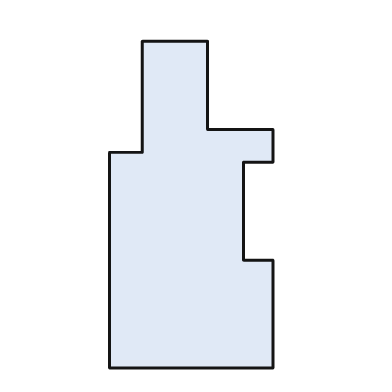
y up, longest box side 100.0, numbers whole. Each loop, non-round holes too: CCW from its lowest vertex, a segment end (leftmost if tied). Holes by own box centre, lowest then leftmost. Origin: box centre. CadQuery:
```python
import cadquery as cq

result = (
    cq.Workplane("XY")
    .moveTo(-25.0, -50.0)
    .lineTo(25.0, -50.0)
    .lineTo(25.0, -17.0)
    .lineTo(16.0, -17.0)
    .lineTo(16.0, 13.0)
    .lineTo(25.0, 13.0)
    .lineTo(25.0, 23.0)
    .lineTo(5.0, 23.0)
    .lineTo(5.0, 50.0)
    .lineTo(-15.0, 50.0)
    .lineTo(-15.0, 16.0)
    .lineTo(-25.0, 16.0)
    .close()
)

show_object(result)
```